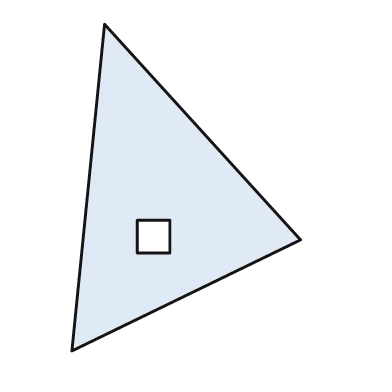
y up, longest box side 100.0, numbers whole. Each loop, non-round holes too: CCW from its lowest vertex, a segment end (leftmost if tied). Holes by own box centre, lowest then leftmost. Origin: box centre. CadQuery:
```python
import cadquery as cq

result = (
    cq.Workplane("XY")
    .moveTo(-35.0, -50.0)
    .lineTo(35.0, -16.0)
    .lineTo(-25.0, 50.0)
    .close()
    .moveTo(-15.0, -20.0)
    .lineTo(-5.0, -20.0)
    .lineTo(-5.0, -10.0)
    .lineTo(-15.0, -10.0)
    .close()
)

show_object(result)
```